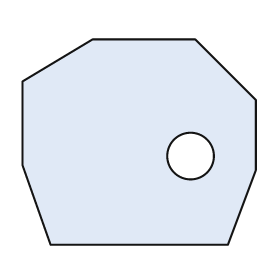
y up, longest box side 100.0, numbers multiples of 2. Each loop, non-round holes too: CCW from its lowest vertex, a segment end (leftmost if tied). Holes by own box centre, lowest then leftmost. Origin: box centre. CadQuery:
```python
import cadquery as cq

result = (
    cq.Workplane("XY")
    .moveTo(-38.0, -44.0)
    .lineTo(38.0, -44.0)
    .lineTo(50.0, -12.0)
    .lineTo(50.0, 18.0)
    .lineTo(24.0, 44.0)
    .lineTo(-20.0, 44.0)
    .lineTo(-50.0, 26.0)
    .lineTo(-50.0, -10.0)
    .close()
    .moveTo(22.0, -6.0)
    .circle(10.0)
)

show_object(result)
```